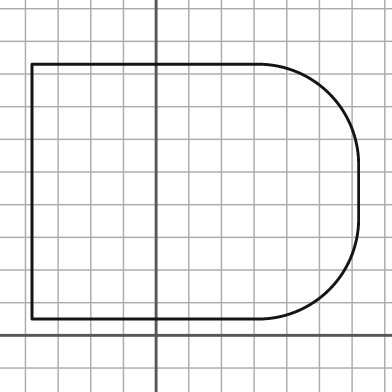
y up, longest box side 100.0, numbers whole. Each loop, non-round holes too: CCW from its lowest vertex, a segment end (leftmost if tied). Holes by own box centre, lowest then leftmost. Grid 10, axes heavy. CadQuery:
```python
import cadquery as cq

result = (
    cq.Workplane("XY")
    .moveTo(-38.0, 5.0)
    .lineTo(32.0, 5.0)
    .threePointArc((53.0, 14.0), (62.0, 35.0))
    .lineTo(62.0, 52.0)
    .threePointArc((53.0, 74.0), (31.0, 83.0))
    .lineTo(-38.0, 83.0)
    .close()
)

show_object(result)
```